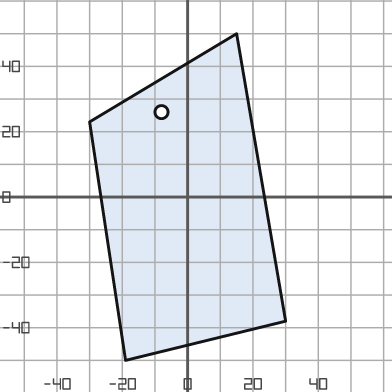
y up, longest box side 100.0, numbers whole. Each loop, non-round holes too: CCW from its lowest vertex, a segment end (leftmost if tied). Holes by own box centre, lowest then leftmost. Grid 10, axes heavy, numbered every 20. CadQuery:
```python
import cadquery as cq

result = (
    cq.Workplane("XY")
    .moveTo(-19.0, -50.0)
    .lineTo(30.0, -38.0)
    .lineTo(15.0, 50.0)
    .lineTo(-30.0, 23.0)
    .close()
    .moveTo(-8.0, 26.0)
    .circle(2.0)
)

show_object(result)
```